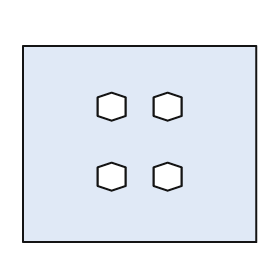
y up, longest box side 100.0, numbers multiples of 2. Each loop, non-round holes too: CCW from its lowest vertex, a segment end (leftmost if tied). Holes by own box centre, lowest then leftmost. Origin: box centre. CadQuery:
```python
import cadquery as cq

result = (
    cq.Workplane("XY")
    .moveTo(-50.0, -42.0)
    .lineTo(50.0, -42.0)
    .lineTo(50.0, 42.0)
    .lineTo(-50.0, 42.0)
    .close()
    .moveTo(-12.0, -20.0)
    .lineTo(-6.0, -18.0)
    .lineTo(-6.0, -10.0)
    .lineTo(-12.0, -8.0)
    .lineTo(-18.0, -10.0)
    .lineTo(-18.0, -18.0)
    .close()
    .moveTo(12.0, -20.0)
    .lineTo(18.0, -18.0)
    .lineTo(18.0, -10.0)
    .lineTo(12.0, -8.0)
    .lineTo(6.0, -10.0)
    .lineTo(6.0, -18.0)
    .close()
    .moveTo(-12.0, 10.0)
    .lineTo(-6.0, 12.0)
    .lineTo(-6.0, 20.0)
    .lineTo(-12.0, 22.0)
    .lineTo(-18.0, 20.0)
    .lineTo(-18.0, 12.0)
    .close()
    .moveTo(12.0, 10.0)
    .lineTo(18.0, 12.0)
    .lineTo(18.0, 20.0)
    .lineTo(12.0, 22.0)
    .lineTo(6.0, 20.0)
    .lineTo(6.0, 12.0)
    .close()
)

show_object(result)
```